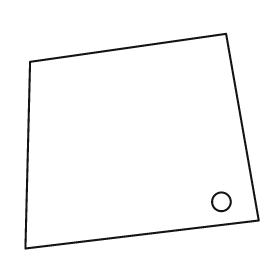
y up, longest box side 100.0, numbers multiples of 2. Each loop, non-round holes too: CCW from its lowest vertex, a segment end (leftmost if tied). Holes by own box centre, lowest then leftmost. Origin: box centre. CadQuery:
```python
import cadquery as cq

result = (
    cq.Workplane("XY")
    .moveTo(-50.0, -46.0)
    .lineTo(50.0, -34.0)
    .lineTo(36.0, 46.0)
    .lineTo(-48.0, 34.0)
    .close()
    .moveTo(34.0, -26.0)
    .circle(4.0)
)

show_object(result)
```